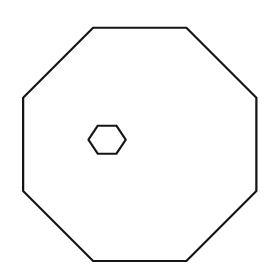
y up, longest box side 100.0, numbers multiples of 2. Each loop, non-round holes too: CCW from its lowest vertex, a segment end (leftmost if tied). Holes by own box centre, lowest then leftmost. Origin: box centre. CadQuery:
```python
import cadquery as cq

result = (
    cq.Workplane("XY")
    .moveTo(-20.0, -50.0)
    .lineTo(20.0, -50.0)
    .lineTo(50.0, -20.0)
    .lineTo(50.0, 20.0)
    .lineTo(20.0, 50.0)
    .lineTo(-20.0, 50.0)
    .lineTo(-50.0, 20.0)
    .lineTo(-50.0, -20.0)
    .close()
    .moveTo(-18.0, -4.0)
    .lineTo(-10.0, -4.0)
    .lineTo(-6.0, 2.0)
    .lineTo(-10.0, 8.0)
    .lineTo(-18.0, 8.0)
    .lineTo(-22.0, 2.0)
    .close()
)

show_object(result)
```